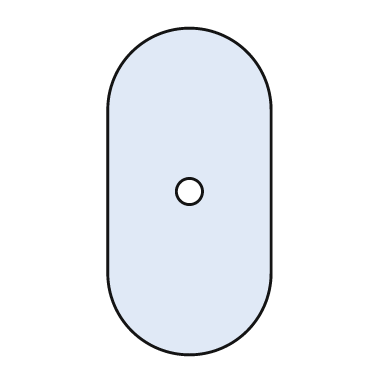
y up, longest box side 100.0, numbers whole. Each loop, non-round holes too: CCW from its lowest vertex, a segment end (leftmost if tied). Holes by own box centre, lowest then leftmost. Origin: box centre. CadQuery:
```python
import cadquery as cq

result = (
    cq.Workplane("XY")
    .moveTo(-25.0, -25.0)
    .threePointArc((0.0, -50.0), (25.0, -25.0))
    .lineTo(25.0, 25.0)
    .threePointArc((0.0, 50.0), (-25.0, 25.0))
    .close()
    .moveTo(0.0, 0.0)
    .circle(4.0)
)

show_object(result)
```